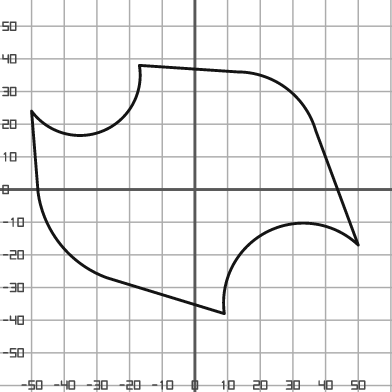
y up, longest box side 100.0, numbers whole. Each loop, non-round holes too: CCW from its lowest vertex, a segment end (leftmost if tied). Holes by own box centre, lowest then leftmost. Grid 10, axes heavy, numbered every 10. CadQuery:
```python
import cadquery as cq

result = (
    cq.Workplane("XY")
    .moveTo(9.0, -38.0)
    .threePointArc((22.0, -13.0), (50.0, -17.0))
    .lineTo(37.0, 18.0)
    .threePointArc((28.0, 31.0), (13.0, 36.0))
    .lineTo(-17.0, 38.0)
    .threePointArc((-28.0, 18.0), (-50.0, 24.0))
    .lineTo(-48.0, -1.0)
    .threePointArc((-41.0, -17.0), (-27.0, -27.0))
    .close()
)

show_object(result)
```